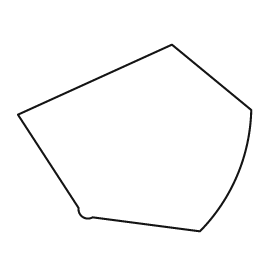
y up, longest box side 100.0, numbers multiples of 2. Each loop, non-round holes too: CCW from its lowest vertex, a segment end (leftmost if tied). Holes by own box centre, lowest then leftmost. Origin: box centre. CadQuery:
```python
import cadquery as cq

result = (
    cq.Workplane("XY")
    .moveTo(28.0, -40.0)
    .threePointArc((44.0, -16.0), (50.0, 12.0))
    .lineTo(16.0, 40.0)
    .lineTo(-50.0, 10.0)
    .lineTo(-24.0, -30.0)
    .threePointArc((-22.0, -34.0), (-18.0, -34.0))
    .close()
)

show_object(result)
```